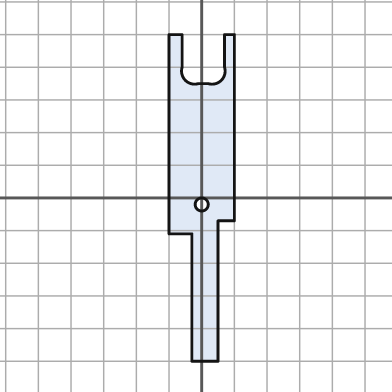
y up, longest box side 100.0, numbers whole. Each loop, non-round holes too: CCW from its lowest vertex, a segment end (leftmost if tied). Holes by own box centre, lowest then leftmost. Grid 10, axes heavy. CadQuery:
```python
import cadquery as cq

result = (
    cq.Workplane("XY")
    .moveTo(-3.0, -50.0)
    .lineTo(5.0, -50.0)
    .lineTo(5.0, -7.0)
    .lineTo(10.0, -7.0)
    .lineTo(10.0, 50.0)
    .lineTo(7.0, 50.0)
    .lineTo(7.0, 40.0)
    .threePointArc((6.0, 36.0), (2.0, 35.0))
    .lineTo(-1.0, 35.0)
    .threePointArc((-5.0, 36.0), (-6.0, 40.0))
    .lineTo(-6.0, 50.0)
    .lineTo(-10.0, 50.0)
    .lineTo(-10.0, -11.0)
    .lineTo(-3.0, -11.0)
    .close()
    .moveTo(0.0, -2.0)
    .circle(2.0)
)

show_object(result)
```